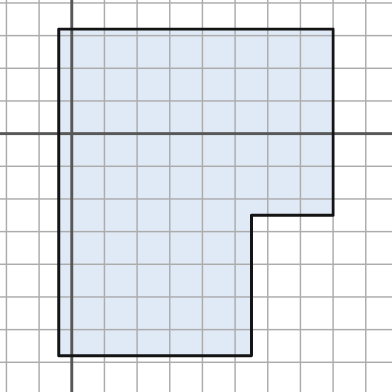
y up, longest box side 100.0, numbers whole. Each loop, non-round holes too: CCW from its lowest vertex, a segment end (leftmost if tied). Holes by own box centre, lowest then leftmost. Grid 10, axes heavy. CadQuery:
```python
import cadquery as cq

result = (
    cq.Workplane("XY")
    .moveTo(-4.0, -68.0)
    .lineTo(55.0, -68.0)
    .lineTo(55.0, -25.0)
    .lineTo(80.0, -25.0)
    .lineTo(80.0, 32.0)
    .lineTo(-4.0, 32.0)
    .close()
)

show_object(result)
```